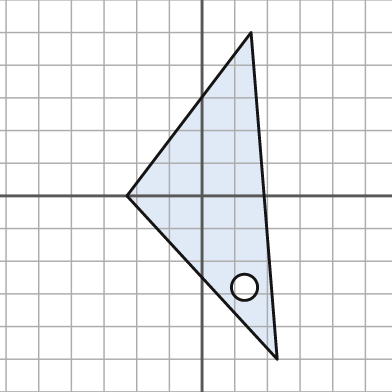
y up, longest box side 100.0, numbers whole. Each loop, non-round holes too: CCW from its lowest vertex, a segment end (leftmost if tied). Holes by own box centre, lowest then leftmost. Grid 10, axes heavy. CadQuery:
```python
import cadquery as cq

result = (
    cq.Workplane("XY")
    .moveTo(23.0, -50.0)
    .lineTo(15.0, 50.0)
    .lineTo(-23.0, 0.0)
    .close()
    .moveTo(13.0, -28.0)
    .circle(4.0)
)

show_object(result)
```